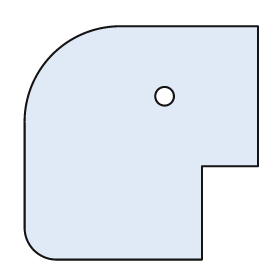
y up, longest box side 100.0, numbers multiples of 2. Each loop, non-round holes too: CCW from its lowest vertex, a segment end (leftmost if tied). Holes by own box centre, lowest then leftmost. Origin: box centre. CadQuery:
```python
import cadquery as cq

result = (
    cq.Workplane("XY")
    .moveTo(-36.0, -50.0)
    .lineTo(26.0, -50.0)
    .lineTo(26.0, -10.0)
    .lineTo(50.0, -10.0)
    .lineTo(50.0, 50.0)
    .lineTo(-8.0, 50.0)
    .threePointArc((-38.0, 38.0), (-50.0, 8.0))
    .lineTo(-50.0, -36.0)
    .threePointArc((-46.0, -46.0), (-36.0, -50.0))
    .close()
    .moveTo(10.0, 20.0)
    .circle(4.0)
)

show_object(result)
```